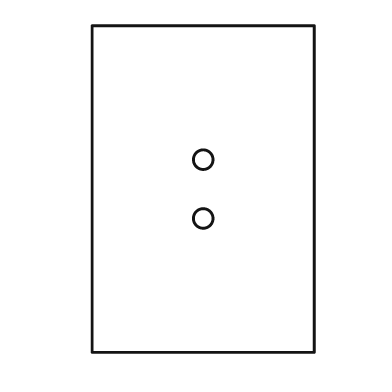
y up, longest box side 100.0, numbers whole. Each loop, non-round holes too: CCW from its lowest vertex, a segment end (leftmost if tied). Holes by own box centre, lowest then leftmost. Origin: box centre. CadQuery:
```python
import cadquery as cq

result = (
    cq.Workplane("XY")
    .moveTo(-34.0, -50.0)
    .lineTo(34.0, -50.0)
    .lineTo(34.0, 50.0)
    .lineTo(-34.0, 50.0)
    .close()
    .moveTo(0.0, -9.0)
    .circle(3.0)
    .moveTo(0.0, 9.0)
    .circle(3.0)
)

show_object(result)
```